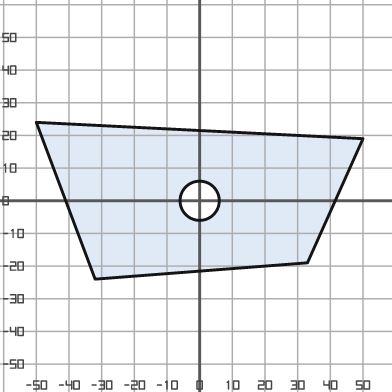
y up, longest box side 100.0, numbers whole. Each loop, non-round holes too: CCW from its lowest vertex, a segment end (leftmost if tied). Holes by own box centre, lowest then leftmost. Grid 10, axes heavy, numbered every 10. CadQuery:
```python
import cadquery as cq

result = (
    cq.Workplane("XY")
    .moveTo(-32.0, -24.0)
    .lineTo(33.0, -19.0)
    .lineTo(50.0, 19.0)
    .lineTo(-50.0, 24.0)
    .close()
    .moveTo(0.0, 0.0)
    .circle(6.0)
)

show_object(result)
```